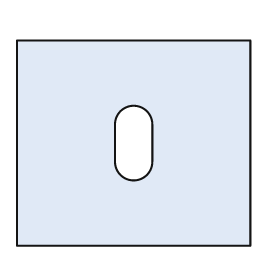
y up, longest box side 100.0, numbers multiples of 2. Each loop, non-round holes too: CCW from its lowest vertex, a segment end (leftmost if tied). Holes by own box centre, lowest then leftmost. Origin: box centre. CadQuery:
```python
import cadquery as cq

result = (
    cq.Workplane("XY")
    .moveTo(-50.0, -44.0)
    .lineTo(50.0, -44.0)
    .lineTo(50.0, 44.0)
    .lineTo(-50.0, 44.0)
    .close()
    .moveTo(-8.0, -8.0)
    .threePointArc((0.0, -16.0), (8.0, -8.0))
    .lineTo(8.0, 8.0)
    .threePointArc((0.0, 16.0), (-8.0, 8.0))
    .close()
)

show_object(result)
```